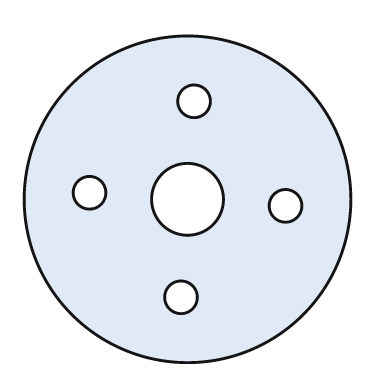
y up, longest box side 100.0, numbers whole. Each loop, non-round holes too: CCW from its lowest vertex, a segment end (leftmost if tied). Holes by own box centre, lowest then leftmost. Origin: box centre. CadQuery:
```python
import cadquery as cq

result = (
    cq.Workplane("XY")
    .moveTo(0.0, 0.0)
    .circle(50.0)
    .moveTo(-2.0, -30.0)
    .circle(5.0)
    .moveTo(30.0, -2.0)
    .circle(5.0)
    .moveTo(0.0, 0.0)
    .circle(11.0)
    .moveTo(-30.0, 2.0)
    .circle(5.0)
    .moveTo(2.0, 30.0)
    .circle(5.0)
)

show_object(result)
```